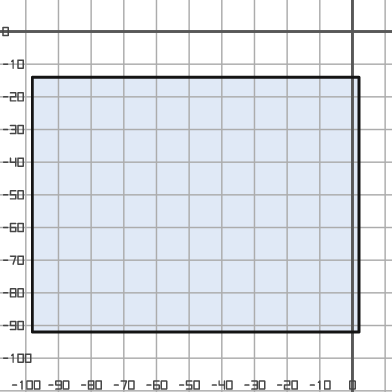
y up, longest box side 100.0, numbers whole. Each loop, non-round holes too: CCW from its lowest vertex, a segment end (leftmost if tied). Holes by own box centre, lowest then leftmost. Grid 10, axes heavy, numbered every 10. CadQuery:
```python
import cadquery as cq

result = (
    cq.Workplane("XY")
    .moveTo(-98.0, -92.0)
    .lineTo(2.0, -92.0)
    .lineTo(2.0, -14.0)
    .lineTo(-98.0, -14.0)
    .close()
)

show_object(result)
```